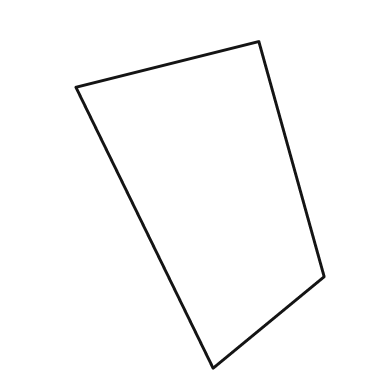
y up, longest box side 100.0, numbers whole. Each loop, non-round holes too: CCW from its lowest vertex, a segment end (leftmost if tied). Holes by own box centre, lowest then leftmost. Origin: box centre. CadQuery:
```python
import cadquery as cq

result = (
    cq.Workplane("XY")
    .moveTo(4.0, -50.0)
    .lineTo(38.0, -22.0)
    .lineTo(18.0, 50.0)
    .lineTo(-38.0, 36.0)
    .close()
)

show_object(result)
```